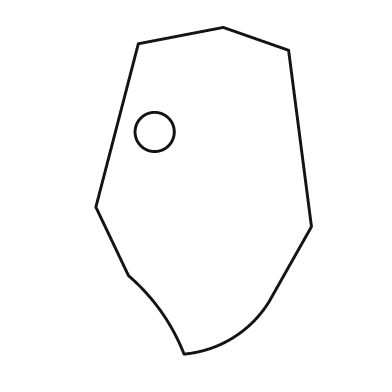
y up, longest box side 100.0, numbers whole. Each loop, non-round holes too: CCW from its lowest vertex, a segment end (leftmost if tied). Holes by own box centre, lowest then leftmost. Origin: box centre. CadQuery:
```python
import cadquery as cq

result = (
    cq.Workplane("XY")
    .moveTo(-6.0, -50.0)
    .threePointArc((9.0, -45.0), (20.0, -34.0))
    .lineTo(33.0, -11.0)
    .lineTo(26.0, 43.0)
    .lineTo(6.0, 50.0)
    .lineTo(-20.0, 45.0)
    .lineTo(-33.0, -5.0)
    .lineTo(-23.0, -26.0)
    .threePointArc((-13.0, -37.0), (-6.0, -50.0))
    .close()
    .moveTo(-15.0, 18.0)
    .circle(6.0)
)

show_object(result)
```